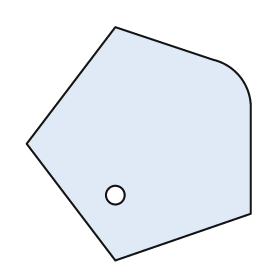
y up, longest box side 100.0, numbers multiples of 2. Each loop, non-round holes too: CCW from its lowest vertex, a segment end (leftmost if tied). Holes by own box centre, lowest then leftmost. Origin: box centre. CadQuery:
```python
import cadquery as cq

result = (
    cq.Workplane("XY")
    .moveTo(-10.0, -50.0)
    .lineTo(48.0, -30.0)
    .lineTo(48.0, 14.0)
    .threePointArc((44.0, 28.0), (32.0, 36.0))
    .lineTo(-10.0, 50.0)
    .lineTo(-48.0, 0.0)
    .close()
    .moveTo(-10.0, -22.0)
    .circle(4.0)
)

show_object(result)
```